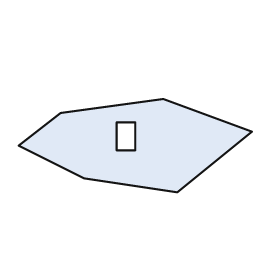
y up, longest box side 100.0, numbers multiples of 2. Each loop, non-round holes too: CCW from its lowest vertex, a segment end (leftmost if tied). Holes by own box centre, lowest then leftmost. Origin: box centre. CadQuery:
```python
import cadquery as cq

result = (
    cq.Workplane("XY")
    .moveTo(18.0, -20.0)
    .lineTo(50.0, 6.0)
    .lineTo(12.0, 20.0)
    .lineTo(-32.0, 14.0)
    .lineTo(-50.0, 0.0)
    .lineTo(-22.0, -14.0)
    .close()
    .moveTo(-8.0, -2.0)
    .lineTo(0.0, -2.0)
    .lineTo(0.0, 10.0)
    .lineTo(-8.0, 10.0)
    .close()
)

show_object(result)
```